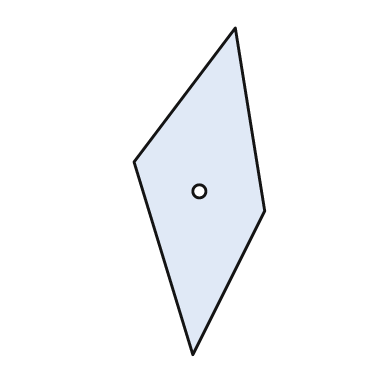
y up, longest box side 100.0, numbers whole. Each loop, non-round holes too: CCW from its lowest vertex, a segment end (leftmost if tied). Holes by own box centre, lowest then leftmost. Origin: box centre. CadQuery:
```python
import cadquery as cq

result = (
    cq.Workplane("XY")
    .moveTo(-2.0, -50.0)
    .lineTo(20.0, -6.0)
    .lineTo(11.0, 50.0)
    .lineTo(-20.0, 9.0)
    .close()
    .moveTo(0.0, 0.0)
    .circle(2.0)
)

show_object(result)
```